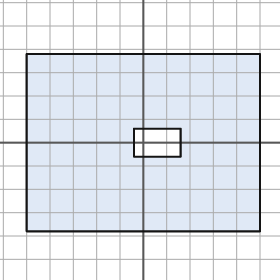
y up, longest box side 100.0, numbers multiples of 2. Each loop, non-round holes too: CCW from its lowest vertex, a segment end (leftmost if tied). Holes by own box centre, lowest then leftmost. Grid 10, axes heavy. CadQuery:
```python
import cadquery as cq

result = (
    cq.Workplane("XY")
    .moveTo(-50.0, -38.0)
    .lineTo(50.0, -38.0)
    .lineTo(50.0, 38.0)
    .lineTo(-50.0, 38.0)
    .close()
    .moveTo(-4.0, -6.0)
    .lineTo(16.0, -6.0)
    .lineTo(16.0, 6.0)
    .lineTo(-4.0, 6.0)
    .close()
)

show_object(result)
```